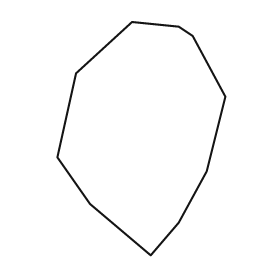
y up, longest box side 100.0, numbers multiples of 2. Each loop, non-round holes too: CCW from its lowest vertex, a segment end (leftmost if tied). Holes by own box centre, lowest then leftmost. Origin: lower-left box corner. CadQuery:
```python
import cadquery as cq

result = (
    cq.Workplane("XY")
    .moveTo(40.0, 0.0)
    .lineTo(52.0, 14.0)
    .lineTo(64.0, 36.0)
    .lineTo(72.0, 68.0)
    .lineTo(58.0, 94.0)
    .lineTo(52.0, 98.0)
    .lineTo(32.0, 100.0)
    .lineTo(8.0, 78.0)
    .lineTo(0.0, 42.0)
    .lineTo(14.0, 22.0)
    .close()
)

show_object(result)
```